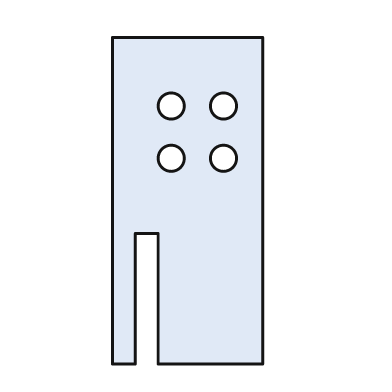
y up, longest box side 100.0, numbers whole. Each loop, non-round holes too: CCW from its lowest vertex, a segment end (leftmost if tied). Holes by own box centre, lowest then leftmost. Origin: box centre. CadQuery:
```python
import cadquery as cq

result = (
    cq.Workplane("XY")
    .moveTo(-23.0, -50.0)
    .lineTo(-16.0, -50.0)
    .lineTo(-16.0, -10.0)
    .lineTo(-9.0, -10.0)
    .lineTo(-9.0, -50.0)
    .lineTo(23.0, -50.0)
    .lineTo(23.0, 50.0)
    .lineTo(-23.0, 50.0)
    .close()
    .moveTo(-5.0, 13.0)
    .circle(4.0)
    .moveTo(11.0, 13.0)
    .circle(4.0)
    .moveTo(-5.0, 29.0)
    .circle(4.0)
    .moveTo(11.0, 29.0)
    .circle(4.0)
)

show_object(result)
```